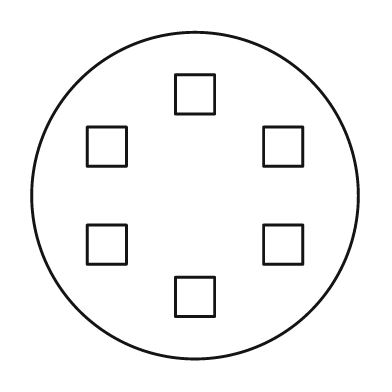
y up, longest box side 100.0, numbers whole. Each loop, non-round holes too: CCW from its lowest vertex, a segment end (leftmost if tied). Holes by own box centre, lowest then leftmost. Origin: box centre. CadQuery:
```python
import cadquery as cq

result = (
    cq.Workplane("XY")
    .moveTo(0.0, 0.0)
    .circle(50.0)
    .moveTo(-6.0, -37.0)
    .lineTo(6.0, -37.0)
    .lineTo(6.0, -25.0)
    .lineTo(-6.0, -25.0)
    .close()
    .moveTo(-33.0, -21.0)
    .lineTo(-21.0, -21.0)
    .lineTo(-21.0, -9.0)
    .lineTo(-33.0, -9.0)
    .close()
    .moveTo(21.0, -21.0)
    .lineTo(33.0, -21.0)
    .lineTo(33.0, -9.0)
    .lineTo(21.0, -9.0)
    .close()
    .moveTo(-33.0, 9.0)
    .lineTo(-21.0, 9.0)
    .lineTo(-21.0, 21.0)
    .lineTo(-33.0, 21.0)
    .close()
    .moveTo(21.0, 9.0)
    .lineTo(33.0, 9.0)
    .lineTo(33.0, 21.0)
    .lineTo(21.0, 21.0)
    .close()
    .moveTo(-6.0, 25.0)
    .lineTo(6.0, 25.0)
    .lineTo(6.0, 37.0)
    .lineTo(-6.0, 37.0)
    .close()
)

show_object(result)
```